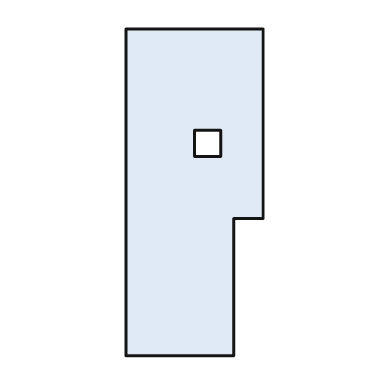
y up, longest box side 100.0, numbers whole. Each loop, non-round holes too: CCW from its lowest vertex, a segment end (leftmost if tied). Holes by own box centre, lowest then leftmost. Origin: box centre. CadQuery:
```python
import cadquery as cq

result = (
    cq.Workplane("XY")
    .moveTo(-21.0, -50.0)
    .lineTo(12.0, -50.0)
    .lineTo(12.0, -8.0)
    .lineTo(21.0, -8.0)
    .lineTo(21.0, 50.0)
    .lineTo(-21.0, 50.0)
    .close()
    .moveTo(0.0, 11.0)
    .lineTo(8.0, 11.0)
    .lineTo(8.0, 19.0)
    .lineTo(0.0, 19.0)
    .close()
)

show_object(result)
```